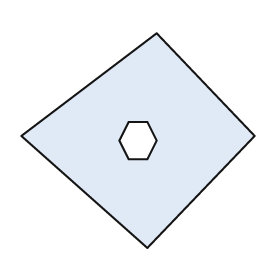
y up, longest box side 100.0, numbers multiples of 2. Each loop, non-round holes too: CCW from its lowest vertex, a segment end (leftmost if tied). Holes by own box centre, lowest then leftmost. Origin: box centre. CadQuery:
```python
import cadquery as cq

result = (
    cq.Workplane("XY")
    .moveTo(4.0, -46.0)
    .lineTo(50.0, 2.0)
    .lineTo(8.0, 46.0)
    .lineTo(-50.0, 2.0)
    .close()
    .moveTo(-4.0, -8.0)
    .lineTo(4.0, -8.0)
    .lineTo(8.0, 0.0)
    .lineTo(4.0, 8.0)
    .lineTo(-4.0, 8.0)
    .lineTo(-8.0, 0.0)
    .close()
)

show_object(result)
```